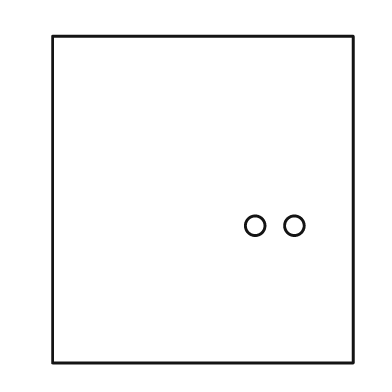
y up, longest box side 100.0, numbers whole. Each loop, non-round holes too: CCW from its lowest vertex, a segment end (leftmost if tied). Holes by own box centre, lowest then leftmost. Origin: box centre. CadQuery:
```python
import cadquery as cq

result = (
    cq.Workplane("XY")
    .moveTo(-46.0, -50.0)
    .lineTo(46.0, -50.0)
    .lineTo(46.0, 50.0)
    .lineTo(-46.0, 50.0)
    .close()
    .moveTo(16.0, -8.0)
    .circle(3.0)
    .moveTo(28.0, -8.0)
    .circle(3.0)
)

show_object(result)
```